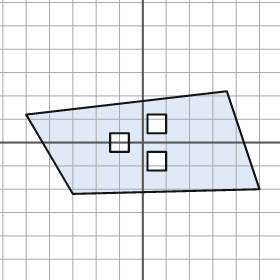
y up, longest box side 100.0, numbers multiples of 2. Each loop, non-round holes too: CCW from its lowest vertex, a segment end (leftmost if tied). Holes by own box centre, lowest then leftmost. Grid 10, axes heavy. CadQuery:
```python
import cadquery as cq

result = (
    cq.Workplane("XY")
    .moveTo(-30.0, -22.0)
    .lineTo(50.0, -20.0)
    .lineTo(36.0, 22.0)
    .lineTo(-50.0, 12.0)
    .close()
    .moveTo(2.0, -12.0)
    .lineTo(10.0, -12.0)
    .lineTo(10.0, -4.0)
    .lineTo(2.0, -4.0)
    .close()
    .moveTo(-14.0, -4.0)
    .lineTo(-6.0, -4.0)
    .lineTo(-6.0, 4.0)
    .lineTo(-14.0, 4.0)
    .close()
    .moveTo(2.0, 4.0)
    .lineTo(10.0, 4.0)
    .lineTo(10.0, 12.0)
    .lineTo(2.0, 12.0)
    .close()
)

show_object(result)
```